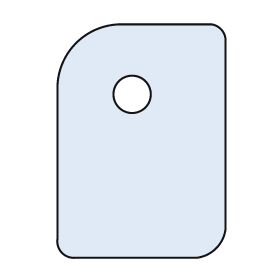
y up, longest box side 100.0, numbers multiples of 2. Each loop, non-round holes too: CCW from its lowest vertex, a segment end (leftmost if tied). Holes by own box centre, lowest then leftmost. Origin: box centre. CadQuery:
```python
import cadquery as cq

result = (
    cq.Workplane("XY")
    .moveTo(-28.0, -50.0)
    .lineTo(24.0, -50.0)
    .threePointArc((32.0, -46.0), (36.0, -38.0))
    .lineTo(36.0, 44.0)
    .threePointArc((34.0, 48.0), (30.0, 50.0))
    .lineTo(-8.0, 50.0)
    .threePointArc((-28.0, 42.0), (-36.0, 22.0))
    .lineTo(-36.0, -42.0)
    .threePointArc((-34.0, -48.0), (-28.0, -50.0))
    .close()
    .moveTo(-4.0, 20.0)
    .circle(8.0)
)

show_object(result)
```